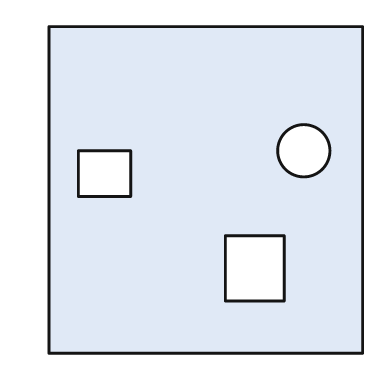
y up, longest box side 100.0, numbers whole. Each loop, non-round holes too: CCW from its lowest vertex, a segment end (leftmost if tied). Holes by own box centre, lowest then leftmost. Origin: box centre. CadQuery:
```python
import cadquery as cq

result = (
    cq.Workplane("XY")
    .moveTo(-48.0, -50.0)
    .lineTo(48.0, -50.0)
    .lineTo(48.0, 50.0)
    .lineTo(-48.0, 50.0)
    .close()
    .moveTo(6.0, -34.0)
    .lineTo(24.0, -34.0)
    .lineTo(24.0, -14.0)
    .lineTo(6.0, -14.0)
    .close()
    .moveTo(-39.0, -2.0)
    .lineTo(-23.0, -2.0)
    .lineTo(-23.0, 12.0)
    .lineTo(-39.0, 12.0)
    .close()
    .moveTo(30.0, 12.0)
    .circle(8.0)
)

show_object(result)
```